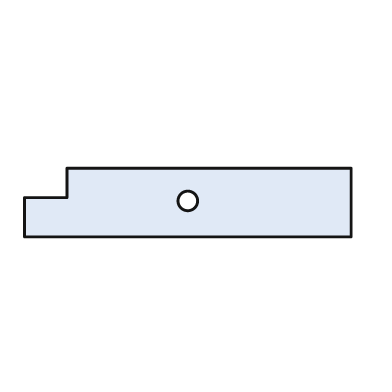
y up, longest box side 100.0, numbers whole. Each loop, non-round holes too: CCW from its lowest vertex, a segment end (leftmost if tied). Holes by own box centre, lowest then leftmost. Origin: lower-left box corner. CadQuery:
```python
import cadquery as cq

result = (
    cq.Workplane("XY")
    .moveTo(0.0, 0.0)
    .lineTo(100.0, 0.0)
    .lineTo(100.0, 21.0)
    .lineTo(13.0, 21.0)
    .lineTo(13.0, 12.0)
    .lineTo(0.0, 12.0)
    .close()
    .moveTo(50.0, 11.0)
    .circle(3.0)
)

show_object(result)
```